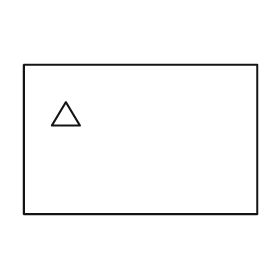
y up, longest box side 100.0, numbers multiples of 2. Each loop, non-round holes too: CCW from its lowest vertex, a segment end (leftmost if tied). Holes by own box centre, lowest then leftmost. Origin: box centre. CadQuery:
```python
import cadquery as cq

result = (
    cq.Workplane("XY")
    .moveTo(-50.0, -32.0)
    .lineTo(50.0, -32.0)
    .lineTo(50.0, 32.0)
    .lineTo(-50.0, 32.0)
    .close()
    .moveTo(-38.0, 6.0)
    .lineTo(-26.0, 6.0)
    .lineTo(-32.0, 16.0)
    .close()
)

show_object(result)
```